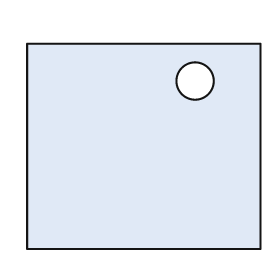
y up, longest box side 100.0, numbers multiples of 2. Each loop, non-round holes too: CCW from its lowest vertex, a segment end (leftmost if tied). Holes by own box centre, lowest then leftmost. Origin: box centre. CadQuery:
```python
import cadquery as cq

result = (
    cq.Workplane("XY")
    .moveTo(-50.0, -44.0)
    .lineTo(50.0, -44.0)
    .lineTo(50.0, 44.0)
    .lineTo(-50.0, 44.0)
    .close()
    .moveTo(22.0, 28.0)
    .circle(8.0)
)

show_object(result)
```